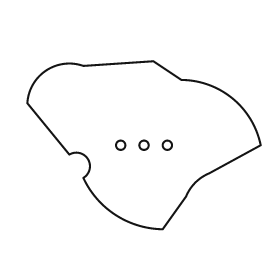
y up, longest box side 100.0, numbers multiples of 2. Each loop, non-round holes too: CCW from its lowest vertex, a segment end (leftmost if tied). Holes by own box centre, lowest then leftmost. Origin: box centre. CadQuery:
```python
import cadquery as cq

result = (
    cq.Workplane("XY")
    .moveTo(8.0, -36.0)
    .lineTo(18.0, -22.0)
    .threePointArc((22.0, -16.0), (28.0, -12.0))
    .lineTo(50.0, 0.0)
    .threePointArc((38.0, 20.0), (16.0, 28.0))
    .lineTo(4.0, 36.0)
    .lineTo(-26.0, 34.0)
    .threePointArc((-42.0, 32.0), (-50.0, 18.0))
    .lineTo(-32.0, -4.0)
    .threePointArc((-24.0, -6.0), (-26.0, -14.0))
    .threePointArc((-12.0, -30.0), (8.0, -36.0))
    .close()
    .moveTo(-10.0, 0.0)
    .circle(2.0)
    .moveTo(0.0, 0.0)
    .circle(2.0)
    .moveTo(10.0, 0.0)
    .circle(2.0)
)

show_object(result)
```